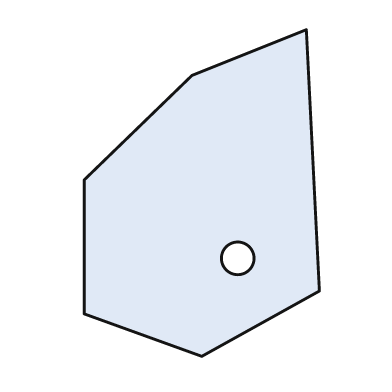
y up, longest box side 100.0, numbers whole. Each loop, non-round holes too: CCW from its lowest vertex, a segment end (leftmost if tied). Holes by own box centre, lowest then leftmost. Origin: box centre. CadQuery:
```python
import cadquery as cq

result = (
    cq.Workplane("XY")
    .moveTo(0.0, -50.0)
    .lineTo(36.0, -30.0)
    .lineTo(32.0, 50.0)
    .lineTo(-3.0, 36.0)
    .lineTo(-36.0, 4.0)
    .lineTo(-36.0, -37.0)
    .close()
    .moveTo(11.0, -20.0)
    .circle(5.0)
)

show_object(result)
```